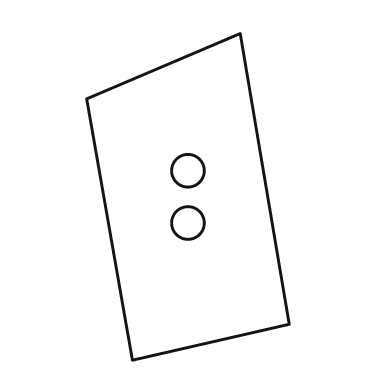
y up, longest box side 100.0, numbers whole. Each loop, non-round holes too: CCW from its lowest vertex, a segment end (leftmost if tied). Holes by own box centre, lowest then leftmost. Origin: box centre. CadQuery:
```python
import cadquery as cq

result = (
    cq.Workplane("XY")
    .moveTo(-17.0, -50.0)
    .lineTo(31.0, -39.0)
    .lineTo(16.0, 50.0)
    .lineTo(-31.0, 30.0)
    .close()
    .moveTo(0.0, -8.0)
    .circle(5.0)
    .moveTo(0.0, 8.0)
    .circle(5.0)
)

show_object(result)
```